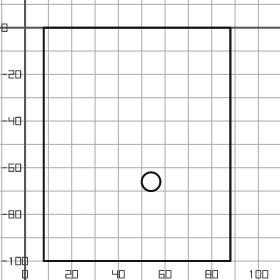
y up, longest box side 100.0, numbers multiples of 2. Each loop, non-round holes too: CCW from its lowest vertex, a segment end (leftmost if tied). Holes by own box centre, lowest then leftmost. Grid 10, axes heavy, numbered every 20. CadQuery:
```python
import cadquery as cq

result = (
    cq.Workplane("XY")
    .moveTo(8.0, -100.0)
    .lineTo(88.0, -100.0)
    .lineTo(88.0, 0.0)
    .lineTo(8.0, 0.0)
    .close()
    .moveTo(54.0, -66.0)
    .circle(4.0)
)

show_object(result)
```